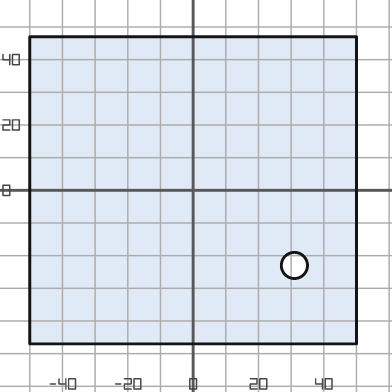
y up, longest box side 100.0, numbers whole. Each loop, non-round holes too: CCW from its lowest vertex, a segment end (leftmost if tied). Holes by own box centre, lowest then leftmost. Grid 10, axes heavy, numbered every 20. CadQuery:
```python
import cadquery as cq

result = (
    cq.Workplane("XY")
    .moveTo(-50.0, -47.0)
    .lineTo(50.0, -47.0)
    .lineTo(50.0, 47.0)
    .lineTo(-50.0, 47.0)
    .close()
    .moveTo(31.0, -23.0)
    .circle(4.0)
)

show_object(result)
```